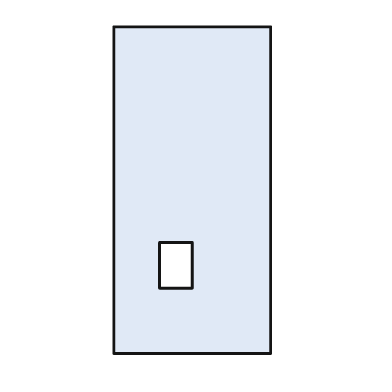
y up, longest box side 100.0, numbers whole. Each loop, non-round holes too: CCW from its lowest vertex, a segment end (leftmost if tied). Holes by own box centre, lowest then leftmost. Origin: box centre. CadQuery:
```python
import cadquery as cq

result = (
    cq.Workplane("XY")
    .moveTo(-24.0, -50.0)
    .lineTo(24.0, -50.0)
    .lineTo(24.0, 50.0)
    .lineTo(-24.0, 50.0)
    .close()
    .moveTo(-10.0, -30.0)
    .lineTo(0.0, -30.0)
    .lineTo(0.0, -16.0)
    .lineTo(-10.0, -16.0)
    .close()
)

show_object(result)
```